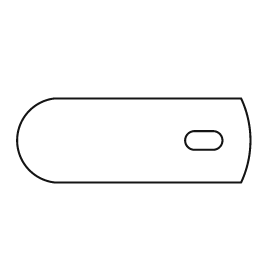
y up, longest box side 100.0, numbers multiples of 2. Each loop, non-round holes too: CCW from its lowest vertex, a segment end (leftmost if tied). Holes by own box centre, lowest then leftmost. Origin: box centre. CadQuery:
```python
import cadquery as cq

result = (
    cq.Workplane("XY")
    .moveTo(-34.0, -18.0)
    .lineTo(46.0, -18.0)
    .threePointArc((50.0, 0.0), (46.0, 18.0))
    .lineTo(-34.0, 18.0)
    .threePointArc((-50.0, 0.0), (-34.0, -18.0))
    .close()
    .moveTo(26.0, -4.0)
    .lineTo(34.0, -4.0)
    .threePointArc((38.0, 0.0), (34.0, 4.0))
    .lineTo(26.0, 4.0)
    .threePointArc((22.0, 0.0), (26.0, -4.0))
    .close()
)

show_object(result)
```